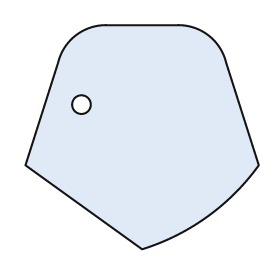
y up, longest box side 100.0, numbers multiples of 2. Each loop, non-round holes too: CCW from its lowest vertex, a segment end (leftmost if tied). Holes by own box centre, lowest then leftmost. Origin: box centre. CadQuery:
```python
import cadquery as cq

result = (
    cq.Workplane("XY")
    .moveTo(0.0, -48.0)
    .threePointArc((28.0, -34.0), (50.0, -12.0))
    .lineTo(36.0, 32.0)
    .threePointArc((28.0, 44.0), (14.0, 48.0))
    .lineTo(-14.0, 48.0)
    .threePointArc((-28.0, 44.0), (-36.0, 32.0))
    .lineTo(-50.0, -12.0)
    .close()
    .moveTo(-26.0, 14.0)
    .circle(4.0)
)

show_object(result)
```